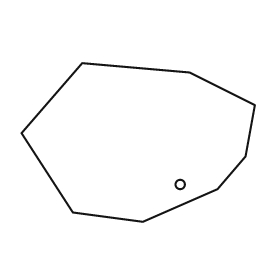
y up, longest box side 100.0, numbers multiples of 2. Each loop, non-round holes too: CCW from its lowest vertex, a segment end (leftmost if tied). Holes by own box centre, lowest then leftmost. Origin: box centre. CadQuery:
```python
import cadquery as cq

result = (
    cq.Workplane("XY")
    .moveTo(2.0, -34.0)
    .lineTo(34.0, -20.0)
    .lineTo(46.0, -6.0)
    .lineTo(50.0, 16.0)
    .lineTo(22.0, 30.0)
    .lineTo(-24.0, 34.0)
    .lineTo(-50.0, 4.0)
    .lineTo(-28.0, -30.0)
    .close()
    .moveTo(18.0, -18.0)
    .circle(2.0)
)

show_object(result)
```